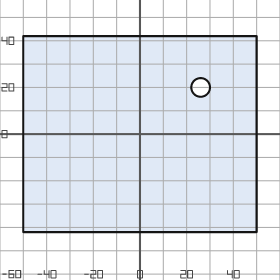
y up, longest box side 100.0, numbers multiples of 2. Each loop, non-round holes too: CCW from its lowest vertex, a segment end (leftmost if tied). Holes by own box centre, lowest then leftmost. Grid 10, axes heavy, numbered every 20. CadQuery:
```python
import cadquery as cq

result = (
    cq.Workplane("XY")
    .moveTo(-50.0, -42.0)
    .lineTo(50.0, -42.0)
    .lineTo(50.0, 42.0)
    .lineTo(-50.0, 42.0)
    .close()
    .moveTo(26.0, 20.0)
    .circle(4.0)
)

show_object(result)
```